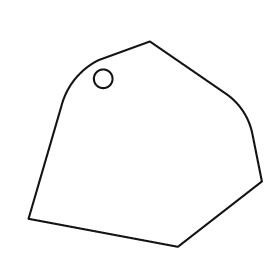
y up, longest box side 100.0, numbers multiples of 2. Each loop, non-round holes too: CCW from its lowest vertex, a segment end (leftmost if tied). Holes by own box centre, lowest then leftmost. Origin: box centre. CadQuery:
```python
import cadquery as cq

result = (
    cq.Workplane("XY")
    .moveTo(14.0, -44.0)
    .lineTo(50.0, -16.0)
    .lineTo(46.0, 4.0)
    .threePointArc((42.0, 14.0), (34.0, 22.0))
    .lineTo(2.0, 44.0)
    .lineTo(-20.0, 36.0)
    .threePointArc((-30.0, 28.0), (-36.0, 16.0))
    .lineTo(-50.0, -32.0)
    .close()
    .moveTo(-18.0, 28.0)
    .circle(4.0)
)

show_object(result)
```